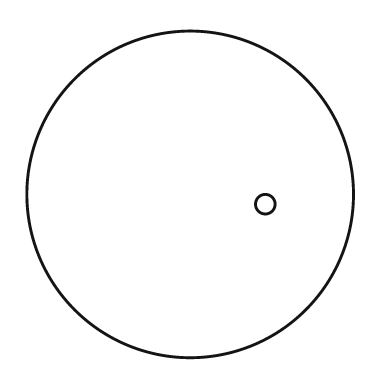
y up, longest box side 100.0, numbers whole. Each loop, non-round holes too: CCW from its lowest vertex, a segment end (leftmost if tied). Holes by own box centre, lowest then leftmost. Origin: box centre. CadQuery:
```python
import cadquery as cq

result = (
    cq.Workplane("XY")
    .moveTo(0.0, 0.0)
    .circle(50.0)
    .moveTo(23.0, -3.0)
    .circle(3.0)
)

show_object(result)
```